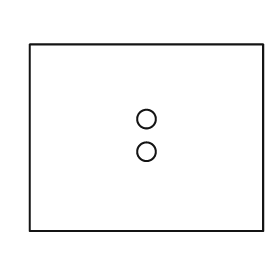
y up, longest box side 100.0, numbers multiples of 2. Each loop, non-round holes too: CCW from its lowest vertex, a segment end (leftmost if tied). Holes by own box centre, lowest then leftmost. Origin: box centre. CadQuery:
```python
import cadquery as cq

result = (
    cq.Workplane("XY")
    .moveTo(-50.0, -40.0)
    .lineTo(50.0, -40.0)
    .lineTo(50.0, 40.0)
    .lineTo(-50.0, 40.0)
    .close()
    .moveTo(0.0, -6.0)
    .circle(4.0)
    .moveTo(0.0, 8.0)
    .circle(4.0)
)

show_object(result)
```